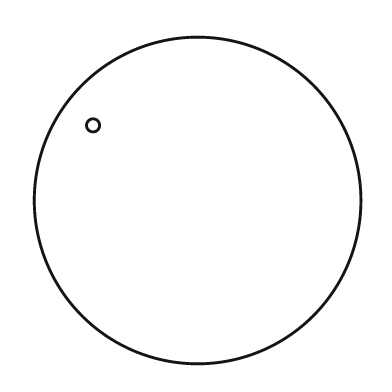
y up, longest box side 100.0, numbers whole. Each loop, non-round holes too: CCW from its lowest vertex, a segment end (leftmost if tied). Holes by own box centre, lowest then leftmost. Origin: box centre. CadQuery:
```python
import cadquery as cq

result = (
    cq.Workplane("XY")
    .moveTo(0.0, 0.0)
    .circle(50.0)
    .moveTo(-32.0, 23.0)
    .circle(2.0)
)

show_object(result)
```